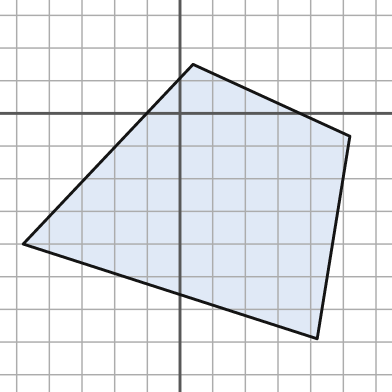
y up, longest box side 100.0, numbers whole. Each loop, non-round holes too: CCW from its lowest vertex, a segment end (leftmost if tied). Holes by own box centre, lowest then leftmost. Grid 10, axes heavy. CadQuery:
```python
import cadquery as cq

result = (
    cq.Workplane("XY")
    .moveTo(42.0, -69.0)
    .lineTo(52.0, -7.0)
    .lineTo(4.0, 15.0)
    .lineTo(-48.0, -40.0)
    .close()
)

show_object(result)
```